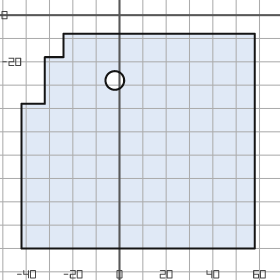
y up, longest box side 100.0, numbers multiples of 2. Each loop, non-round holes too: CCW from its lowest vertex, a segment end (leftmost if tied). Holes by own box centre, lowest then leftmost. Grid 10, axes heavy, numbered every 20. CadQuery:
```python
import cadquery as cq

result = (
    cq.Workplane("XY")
    .moveTo(-42.0, -100.0)
    .lineTo(58.0, -100.0)
    .lineTo(58.0, -8.0)
    .lineTo(-24.0, -8.0)
    .lineTo(-24.0, -18.0)
    .lineTo(-32.0, -18.0)
    .lineTo(-32.0, -38.0)
    .lineTo(-42.0, -38.0)
    .close()
    .moveTo(-2.0, -28.0)
    .circle(4.0)
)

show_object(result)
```